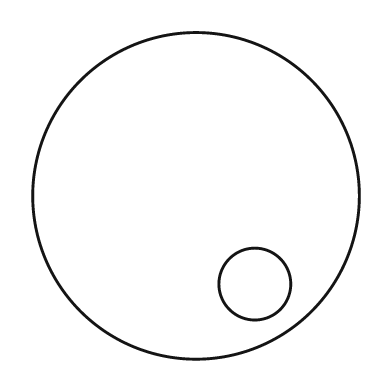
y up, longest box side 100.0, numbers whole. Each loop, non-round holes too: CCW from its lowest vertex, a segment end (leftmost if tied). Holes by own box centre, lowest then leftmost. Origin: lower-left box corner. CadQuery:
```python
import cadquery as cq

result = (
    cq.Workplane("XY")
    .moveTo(50.0, 50.0)
    .circle(50.0)
    .moveTo(68.0, 23.0)
    .circle(11.0)
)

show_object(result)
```